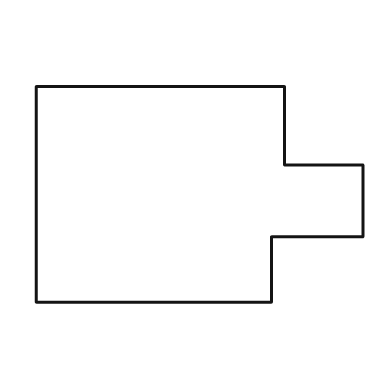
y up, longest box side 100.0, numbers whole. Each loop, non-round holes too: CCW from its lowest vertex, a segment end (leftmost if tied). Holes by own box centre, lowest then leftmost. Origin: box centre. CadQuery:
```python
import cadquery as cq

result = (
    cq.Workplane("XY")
    .moveTo(-50.0, -33.0)
    .lineTo(22.0, -33.0)
    .lineTo(22.0, -13.0)
    .lineTo(50.0, -13.0)
    .lineTo(50.0, 9.0)
    .lineTo(26.0, 9.0)
    .lineTo(26.0, 33.0)
    .lineTo(-50.0, 33.0)
    .close()
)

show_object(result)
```